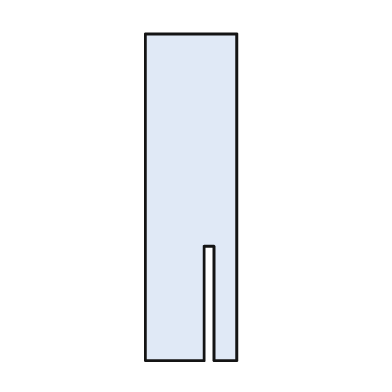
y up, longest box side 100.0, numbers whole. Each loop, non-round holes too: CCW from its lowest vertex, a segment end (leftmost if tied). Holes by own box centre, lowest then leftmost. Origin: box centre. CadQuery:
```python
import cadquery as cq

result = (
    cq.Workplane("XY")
    .moveTo(-14.0, -50.0)
    .lineTo(4.0, -50.0)
    .lineTo(4.0, -15.0)
    .lineTo(7.0, -15.0)
    .lineTo(7.0, -50.0)
    .lineTo(14.0, -50.0)
    .lineTo(14.0, 50.0)
    .lineTo(-14.0, 50.0)
    .close()
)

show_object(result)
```